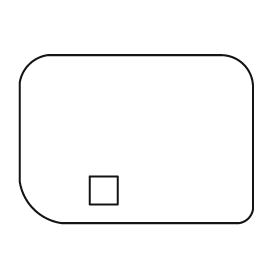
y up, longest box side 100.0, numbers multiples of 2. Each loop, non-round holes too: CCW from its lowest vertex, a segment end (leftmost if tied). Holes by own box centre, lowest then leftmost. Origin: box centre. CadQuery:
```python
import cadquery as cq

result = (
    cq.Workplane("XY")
    .moveTo(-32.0, -36.0)
    .lineTo(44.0, -36.0)
    .threePointArc((48.0, -34.0), (50.0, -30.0))
    .lineTo(50.0, 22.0)
    .threePointArc((46.0, 32.0), (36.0, 36.0))
    .lineTo(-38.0, 36.0)
    .threePointArc((-46.0, 32.0), (-50.0, 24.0))
    .lineTo(-50.0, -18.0)
    .threePointArc((-44.0, -30.0), (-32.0, -36.0))
    .close()
    .moveTo(-20.0, -28.0)
    .lineTo(-8.0, -28.0)
    .lineTo(-8.0, -16.0)
    .lineTo(-20.0, -16.0)
    .close()
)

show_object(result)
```